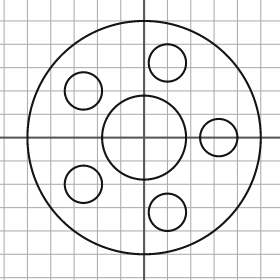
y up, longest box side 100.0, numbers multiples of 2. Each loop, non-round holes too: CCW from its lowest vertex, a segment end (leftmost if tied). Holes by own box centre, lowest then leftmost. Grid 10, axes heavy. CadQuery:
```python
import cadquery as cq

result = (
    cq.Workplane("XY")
    .moveTo(0.0, 0.0)
    .circle(50.0)
    .moveTo(10.0, -32.0)
    .circle(8.0)
    .moveTo(-26.0, -20.0)
    .circle(8.0)
    .moveTo(0.0, 0.0)
    .circle(18.0)
    .moveTo(32.0, 0.0)
    .circle(8.0)
    .moveTo(-26.0, 20.0)
    .circle(8.0)
    .moveTo(10.0, 32.0)
    .circle(8.0)
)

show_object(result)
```